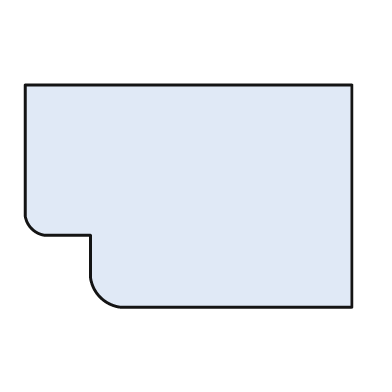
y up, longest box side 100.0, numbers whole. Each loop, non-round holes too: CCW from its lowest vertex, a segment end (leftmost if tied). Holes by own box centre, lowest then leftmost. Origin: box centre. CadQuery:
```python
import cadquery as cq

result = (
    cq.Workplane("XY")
    .moveTo(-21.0, -34.0)
    .lineTo(50.0, -34.0)
    .lineTo(50.0, 34.0)
    .lineTo(-50.0, 34.0)
    .lineTo(-50.0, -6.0)
    .threePointArc((-48.0, -10.0), (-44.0, -12.0))
    .lineTo(-30.0, -12.0)
    .lineTo(-30.0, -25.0)
    .threePointArc((-27.0, -31.0), (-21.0, -34.0))
    .close()
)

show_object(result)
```